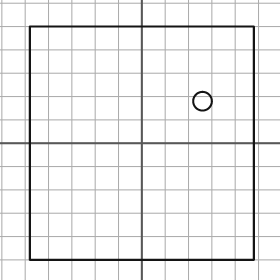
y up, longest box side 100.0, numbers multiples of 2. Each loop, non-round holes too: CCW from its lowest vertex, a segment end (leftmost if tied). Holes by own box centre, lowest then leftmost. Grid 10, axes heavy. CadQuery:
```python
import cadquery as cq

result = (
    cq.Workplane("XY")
    .moveTo(-48.0, -50.0)
    .lineTo(48.0, -50.0)
    .lineTo(48.0, 50.0)
    .lineTo(-48.0, 50.0)
    .close()
    .moveTo(26.0, 18.0)
    .circle(4.0)
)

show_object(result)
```